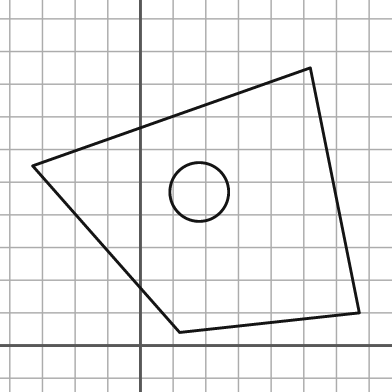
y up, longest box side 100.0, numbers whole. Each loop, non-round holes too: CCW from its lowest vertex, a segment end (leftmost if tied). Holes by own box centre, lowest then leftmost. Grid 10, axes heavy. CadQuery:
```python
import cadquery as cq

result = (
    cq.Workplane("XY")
    .moveTo(12.0, 4.0)
    .lineTo(67.0, 10.0)
    .lineTo(52.0, 85.0)
    .lineTo(-33.0, 55.0)
    .close()
    .moveTo(18.0, 47.0)
    .circle(9.0)
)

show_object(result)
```